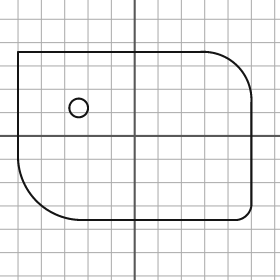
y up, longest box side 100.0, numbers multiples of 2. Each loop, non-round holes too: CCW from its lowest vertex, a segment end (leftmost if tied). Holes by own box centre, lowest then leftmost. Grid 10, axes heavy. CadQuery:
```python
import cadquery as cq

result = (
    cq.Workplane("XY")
    .moveTo(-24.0, -36.0)
    .lineTo(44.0, -36.0)
    .threePointArc((48.0, -34.0), (50.0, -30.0))
    .lineTo(50.0, 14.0)
    .threePointArc((44.0, 30.0), (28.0, 36.0))
    .lineTo(-50.0, 36.0)
    .lineTo(-50.0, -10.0)
    .threePointArc((-42.0, -28.0), (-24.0, -36.0))
    .close()
    .moveTo(-24.0, 12.0)
    .circle(4.0)
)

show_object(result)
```